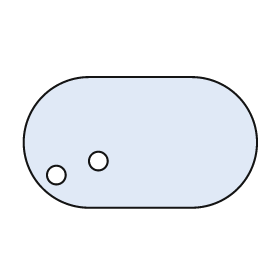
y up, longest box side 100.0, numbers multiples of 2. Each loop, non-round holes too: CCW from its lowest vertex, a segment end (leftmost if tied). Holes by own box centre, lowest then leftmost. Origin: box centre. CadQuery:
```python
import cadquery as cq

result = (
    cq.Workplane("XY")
    .moveTo(-22.0, -28.0)
    .lineTo(22.0, -28.0)
    .threePointArc((50.0, 0.0), (22.0, 28.0))
    .lineTo(-22.0, 28.0)
    .threePointArc((-50.0, 0.0), (-22.0, -28.0))
    .close()
    .moveTo(-36.0, -14.0)
    .circle(4.0)
    .moveTo(-18.0, -8.0)
    .circle(4.0)
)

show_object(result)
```